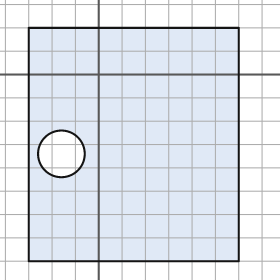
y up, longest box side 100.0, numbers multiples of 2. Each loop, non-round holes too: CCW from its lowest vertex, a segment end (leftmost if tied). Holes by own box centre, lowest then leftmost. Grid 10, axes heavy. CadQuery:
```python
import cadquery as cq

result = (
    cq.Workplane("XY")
    .moveTo(-30.0, -80.0)
    .lineTo(60.0, -80.0)
    .lineTo(60.0, 20.0)
    .lineTo(-30.0, 20.0)
    .close()
    .moveTo(-16.0, -34.0)
    .circle(10.0)
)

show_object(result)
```